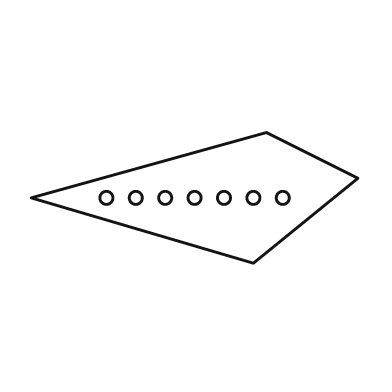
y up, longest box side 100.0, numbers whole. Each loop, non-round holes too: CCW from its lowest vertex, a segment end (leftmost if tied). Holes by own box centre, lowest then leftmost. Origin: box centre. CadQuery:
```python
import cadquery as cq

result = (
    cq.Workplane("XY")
    .moveTo(18.0, -20.0)
    .lineTo(50.0, 6.0)
    .lineTo(22.0, 20.0)
    .lineTo(-50.0, 0.0)
    .close()
    .moveTo(-27.0, 0.0)
    .circle(2.0)
    .moveTo(-18.0, 0.0)
    .circle(2.0)
    .moveTo(-9.0, 0.0)
    .circle(2.0)
    .moveTo(0.0, 0.0)
    .circle(2.0)
    .moveTo(9.0, 0.0)
    .circle(2.0)
    .moveTo(18.0, 0.0)
    .circle(2.0)
    .moveTo(27.0, 0.0)
    .circle(2.0)
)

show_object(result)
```